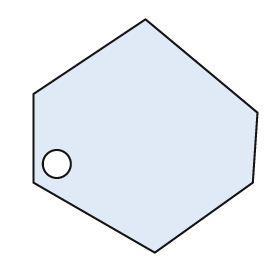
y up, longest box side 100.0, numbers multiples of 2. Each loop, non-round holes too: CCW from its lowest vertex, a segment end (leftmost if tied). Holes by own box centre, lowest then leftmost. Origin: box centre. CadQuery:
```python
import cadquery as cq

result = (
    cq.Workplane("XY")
    .moveTo(4.0, -50.0)
    .lineTo(46.0, -20.0)
    .lineTo(48.0, 10.0)
    .lineTo(0.0, 50.0)
    .lineTo(-48.0, 18.0)
    .lineTo(-48.0, -20.0)
    .close()
    .moveTo(-38.0, -12.0)
    .circle(6.0)
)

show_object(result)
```